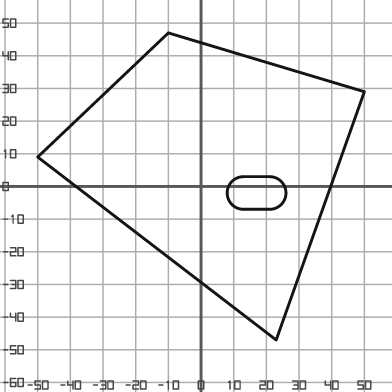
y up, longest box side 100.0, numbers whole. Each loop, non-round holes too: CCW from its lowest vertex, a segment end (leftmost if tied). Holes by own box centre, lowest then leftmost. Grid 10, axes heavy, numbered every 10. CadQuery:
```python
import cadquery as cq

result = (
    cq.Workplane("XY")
    .moveTo(23.0, -47.0)
    .lineTo(50.0, 29.0)
    .lineTo(-10.0, 47.0)
    .lineTo(-50.0, 9.0)
    .close()
    .moveTo(13.0, -7.0)
    .lineTo(21.0, -7.0)
    .threePointArc((26.0, -2.0), (21.0, 3.0))
    .lineTo(13.0, 3.0)
    .threePointArc((8.0, -2.0), (13.0, -7.0))
    .close()
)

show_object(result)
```